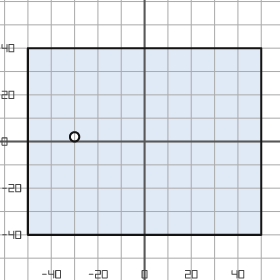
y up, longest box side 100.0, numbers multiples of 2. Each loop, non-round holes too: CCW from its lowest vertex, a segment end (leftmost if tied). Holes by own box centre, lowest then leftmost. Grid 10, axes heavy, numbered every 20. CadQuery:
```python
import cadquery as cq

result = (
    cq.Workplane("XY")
    .moveTo(-50.0, -40.0)
    .lineTo(50.0, -40.0)
    .lineTo(50.0, 40.0)
    .lineTo(-50.0, 40.0)
    .close()
    .moveTo(-30.0, 2.0)
    .circle(2.0)
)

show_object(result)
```